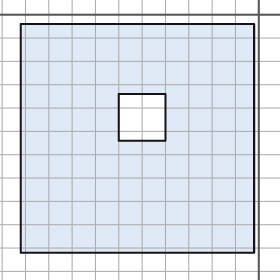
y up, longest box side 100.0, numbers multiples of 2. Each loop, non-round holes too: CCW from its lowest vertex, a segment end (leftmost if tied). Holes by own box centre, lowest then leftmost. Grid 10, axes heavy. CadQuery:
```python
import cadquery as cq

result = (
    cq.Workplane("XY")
    .moveTo(-102.0, -102.0)
    .lineTo(-2.0, -102.0)
    .lineTo(-2.0, -4.0)
    .lineTo(-102.0, -4.0)
    .close()
    .moveTo(-60.0, -54.0)
    .lineTo(-40.0, -54.0)
    .lineTo(-40.0, -34.0)
    .lineTo(-60.0, -34.0)
    .close()
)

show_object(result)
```